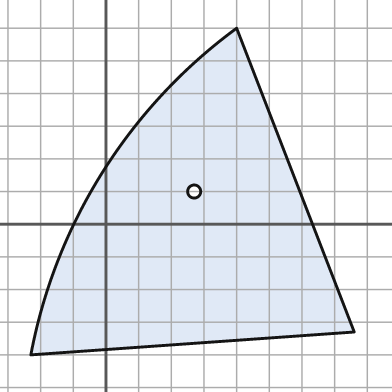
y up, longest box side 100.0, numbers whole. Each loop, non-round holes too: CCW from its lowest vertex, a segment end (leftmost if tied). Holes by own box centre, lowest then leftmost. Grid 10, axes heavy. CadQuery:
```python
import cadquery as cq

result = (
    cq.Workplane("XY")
    .moveTo(-23.0, -40.0)
    .lineTo(76.0, -33.0)
    .lineTo(40.0, 60.0)
    .threePointArc((-1.0, 16.0), (-23.0, -40.0))
    .close()
    .moveTo(27.0, 10.0)
    .circle(2.0)
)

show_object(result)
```